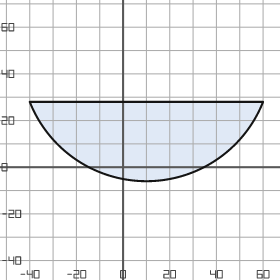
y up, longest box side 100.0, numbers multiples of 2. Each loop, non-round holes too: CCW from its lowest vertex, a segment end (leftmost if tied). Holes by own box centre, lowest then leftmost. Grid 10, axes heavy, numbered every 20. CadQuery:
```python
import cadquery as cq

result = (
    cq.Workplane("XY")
    .moveTo(-40.0, 28.0)
    .threePointArc((10.0, -6.0), (60.0, 28.0))
    .close()
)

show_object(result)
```